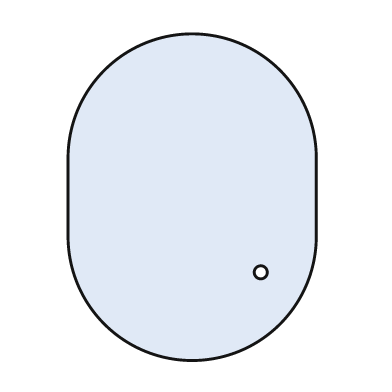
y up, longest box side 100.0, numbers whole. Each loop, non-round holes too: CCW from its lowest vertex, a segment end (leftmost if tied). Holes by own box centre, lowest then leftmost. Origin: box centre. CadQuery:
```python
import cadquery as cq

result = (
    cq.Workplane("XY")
    .moveTo(-38.0, -12.0)
    .threePointArc((0.0, -50.0), (38.0, -12.0))
    .lineTo(38.0, 12.0)
    .threePointArc((0.0, 50.0), (-38.0, 12.0))
    .close()
    .moveTo(21.0, -23.0)
    .circle(2.0)
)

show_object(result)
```